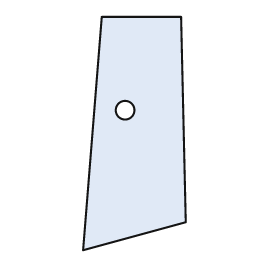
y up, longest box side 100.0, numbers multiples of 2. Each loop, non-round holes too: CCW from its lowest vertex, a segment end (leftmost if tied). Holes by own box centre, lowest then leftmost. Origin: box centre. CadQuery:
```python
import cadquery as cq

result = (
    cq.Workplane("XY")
    .moveTo(-22.0, -50.0)
    .lineTo(22.0, -38.0)
    .lineTo(20.0, 50.0)
    .lineTo(-14.0, 50.0)
    .close()
    .moveTo(-4.0, 10.0)
    .circle(4.0)
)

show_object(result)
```